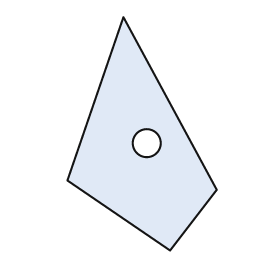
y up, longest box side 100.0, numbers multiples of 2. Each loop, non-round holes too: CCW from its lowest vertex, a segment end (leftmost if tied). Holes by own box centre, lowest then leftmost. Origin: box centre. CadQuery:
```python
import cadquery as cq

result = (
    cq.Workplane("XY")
    .moveTo(12.0, -50.0)
    .lineTo(32.0, -24.0)
    .lineTo(-8.0, 50.0)
    .lineTo(-32.0, -20.0)
    .close()
    .moveTo(2.0, -4.0)
    .circle(6.0)
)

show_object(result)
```